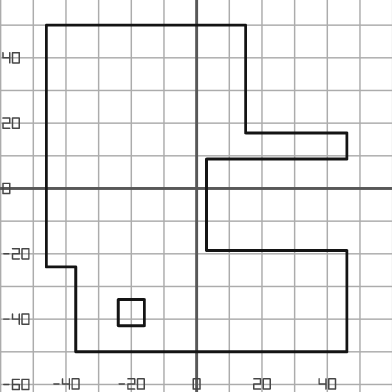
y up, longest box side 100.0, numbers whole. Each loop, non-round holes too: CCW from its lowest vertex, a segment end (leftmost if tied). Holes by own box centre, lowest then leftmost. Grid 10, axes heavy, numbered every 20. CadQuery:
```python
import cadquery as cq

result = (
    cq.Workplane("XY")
    .moveTo(-37.0, -50.0)
    .lineTo(46.0, -50.0)
    .lineTo(46.0, -19.0)
    .lineTo(3.0, -19.0)
    .lineTo(3.0, 9.0)
    .lineTo(46.0, 9.0)
    .lineTo(46.0, 17.0)
    .lineTo(15.0, 17.0)
    .lineTo(15.0, 50.0)
    .lineTo(-46.0, 50.0)
    .lineTo(-46.0, -24.0)
    .lineTo(-37.0, -24.0)
    .close()
    .moveTo(-24.0, -42.0)
    .lineTo(-16.0, -42.0)
    .lineTo(-16.0, -34.0)
    .lineTo(-24.0, -34.0)
    .close()
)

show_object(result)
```